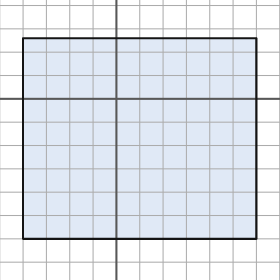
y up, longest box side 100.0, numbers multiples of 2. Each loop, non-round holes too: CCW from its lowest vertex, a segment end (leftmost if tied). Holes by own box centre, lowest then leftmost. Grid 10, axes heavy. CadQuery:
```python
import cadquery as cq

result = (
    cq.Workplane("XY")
    .moveTo(-40.0, -60.0)
    .lineTo(60.0, -60.0)
    .lineTo(60.0, 26.0)
    .lineTo(-40.0, 26.0)
    .close()
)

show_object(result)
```